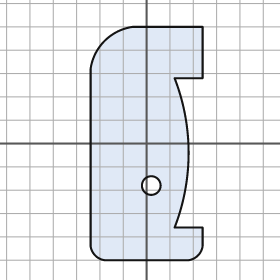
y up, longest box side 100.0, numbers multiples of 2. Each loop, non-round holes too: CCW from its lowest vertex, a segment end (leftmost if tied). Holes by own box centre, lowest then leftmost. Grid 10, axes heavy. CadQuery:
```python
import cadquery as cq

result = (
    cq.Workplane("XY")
    .moveTo(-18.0, -50.0)
    .lineTo(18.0, -50.0)
    .threePointArc((22.0, -48.0), (24.0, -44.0))
    .lineTo(24.0, -36.0)
    .lineTo(12.0, -36.0)
    .threePointArc((18.0, -4.0), (12.0, 28.0))
    .lineTo(24.0, 28.0)
    .lineTo(24.0, 50.0)
    .lineTo(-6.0, 50.0)
    .threePointArc((-18.0, 44.0), (-24.0, 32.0))
    .lineTo(-24.0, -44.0)
    .threePointArc((-22.0, -48.0), (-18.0, -50.0))
    .close()
    .moveTo(2.0, -18.0)
    .circle(4.0)
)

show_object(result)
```